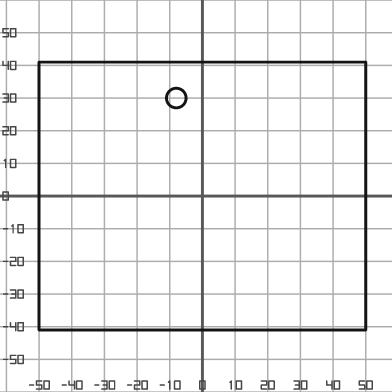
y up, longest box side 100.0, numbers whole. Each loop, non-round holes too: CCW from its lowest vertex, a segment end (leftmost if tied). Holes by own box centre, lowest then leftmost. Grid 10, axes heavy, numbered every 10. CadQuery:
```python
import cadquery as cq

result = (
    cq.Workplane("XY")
    .moveTo(-50.0, -41.0)
    .lineTo(50.0, -41.0)
    .lineTo(50.0, 41.0)
    .lineTo(-50.0, 41.0)
    .close()
    .moveTo(-8.0, 30.0)
    .circle(3.0)
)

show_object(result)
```